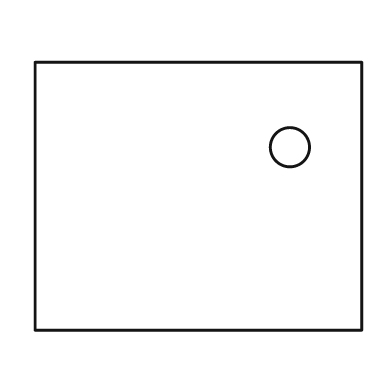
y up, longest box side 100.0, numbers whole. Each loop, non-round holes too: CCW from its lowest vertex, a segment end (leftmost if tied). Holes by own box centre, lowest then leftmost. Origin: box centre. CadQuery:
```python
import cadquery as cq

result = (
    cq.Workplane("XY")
    .moveTo(-50.0, -41.0)
    .lineTo(50.0, -41.0)
    .lineTo(50.0, 41.0)
    .lineTo(-50.0, 41.0)
    .close()
    .moveTo(28.0, 15.0)
    .circle(6.0)
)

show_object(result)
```